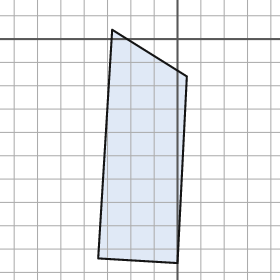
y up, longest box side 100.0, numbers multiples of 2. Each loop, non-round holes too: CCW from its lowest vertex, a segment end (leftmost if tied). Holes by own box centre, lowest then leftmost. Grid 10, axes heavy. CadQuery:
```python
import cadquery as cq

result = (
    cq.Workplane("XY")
    .moveTo(0.0, -96.0)
    .lineTo(4.0, -16.0)
    .lineTo(-28.0, 4.0)
    .lineTo(-34.0, -94.0)
    .close()
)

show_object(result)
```